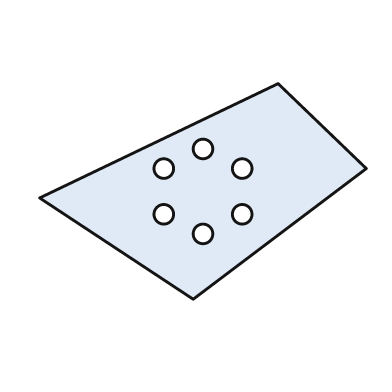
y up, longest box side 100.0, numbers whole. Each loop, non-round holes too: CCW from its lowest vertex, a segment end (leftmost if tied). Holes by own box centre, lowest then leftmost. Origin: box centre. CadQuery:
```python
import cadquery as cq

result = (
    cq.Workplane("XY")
    .moveTo(-3.0, -33.0)
    .lineTo(50.0, 7.0)
    .lineTo(23.0, 33.0)
    .lineTo(-50.0, -2.0)
    .close()
    .moveTo(0.0, -13.0)
    .circle(3.0)
    .moveTo(-12.0, -7.0)
    .circle(3.0)
    .moveTo(12.0, -7.0)
    .circle(3.0)
    .moveTo(-12.0, 7.0)
    .circle(3.0)
    .moveTo(12.0, 7.0)
    .circle(3.0)
    .moveTo(0.0, 13.0)
    .circle(3.0)
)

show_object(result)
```